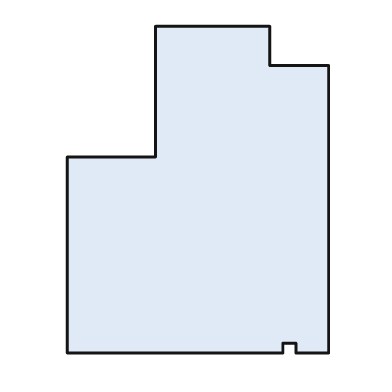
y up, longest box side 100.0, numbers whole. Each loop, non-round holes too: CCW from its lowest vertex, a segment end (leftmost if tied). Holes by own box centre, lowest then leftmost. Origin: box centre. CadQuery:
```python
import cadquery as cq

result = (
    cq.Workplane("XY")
    .moveTo(-40.0, -50.0)
    .lineTo(26.0, -50.0)
    .lineTo(26.0, -47.0)
    .lineTo(30.0, -47.0)
    .lineTo(30.0, -50.0)
    .lineTo(40.0, -50.0)
    .lineTo(40.0, 38.0)
    .lineTo(22.0, 38.0)
    .lineTo(22.0, 50.0)
    .lineTo(-13.0, 50.0)
    .lineTo(-13.0, 10.0)
    .lineTo(-40.0, 10.0)
    .close()
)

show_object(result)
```